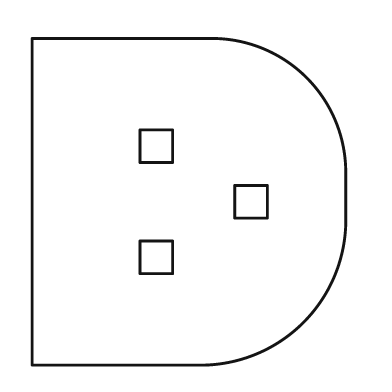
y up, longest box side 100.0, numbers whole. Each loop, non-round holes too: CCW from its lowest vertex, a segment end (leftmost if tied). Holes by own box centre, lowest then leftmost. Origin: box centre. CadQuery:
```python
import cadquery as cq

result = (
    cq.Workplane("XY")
    .moveTo(-48.0, -50.0)
    .lineTo(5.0, -50.0)
    .threePointArc((35.0, -37.0), (48.0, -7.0))
    .lineTo(48.0, 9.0)
    .threePointArc((36.0, 38.0), (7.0, 50.0))
    .lineTo(-48.0, 50.0)
    .close()
    .moveTo(-15.0, -22.0)
    .lineTo(-5.0, -22.0)
    .lineTo(-5.0, -12.0)
    .lineTo(-15.0, -12.0)
    .close()
    .moveTo(14.0, -5.0)
    .lineTo(24.0, -5.0)
    .lineTo(24.0, 5.0)
    .lineTo(14.0, 5.0)
    .close()
    .moveTo(-15.0, 12.0)
    .lineTo(-5.0, 12.0)
    .lineTo(-5.0, 22.0)
    .lineTo(-15.0, 22.0)
    .close()
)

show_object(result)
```